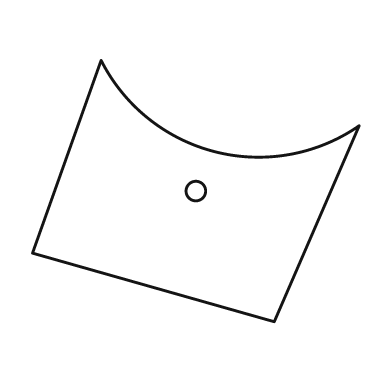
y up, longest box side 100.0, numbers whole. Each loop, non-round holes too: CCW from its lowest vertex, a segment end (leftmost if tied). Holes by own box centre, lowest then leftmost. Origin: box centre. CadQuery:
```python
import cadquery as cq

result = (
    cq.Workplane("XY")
    .moveTo(24.0, -40.0)
    .lineTo(50.0, 20.0)
    .threePointArc((6.0, 12.0), (-29.0, 40.0))
    .lineTo(-50.0, -19.0)
    .close()
    .moveTo(0.0, 0.0)
    .circle(3.0)
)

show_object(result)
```